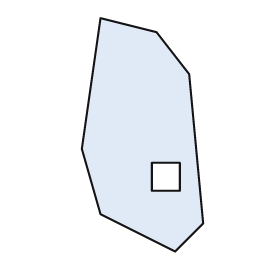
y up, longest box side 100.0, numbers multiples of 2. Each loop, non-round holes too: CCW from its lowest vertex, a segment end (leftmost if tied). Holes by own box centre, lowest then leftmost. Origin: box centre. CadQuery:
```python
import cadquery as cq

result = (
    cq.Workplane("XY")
    .moveTo(14.0, -50.0)
    .lineTo(26.0, -38.0)
    .lineTo(20.0, 26.0)
    .lineTo(6.0, 44.0)
    .lineTo(-18.0, 50.0)
    .lineTo(-26.0, -6.0)
    .lineTo(-18.0, -34.0)
    .close()
    .moveTo(4.0, -24.0)
    .lineTo(16.0, -24.0)
    .lineTo(16.0, -12.0)
    .lineTo(4.0, -12.0)
    .close()
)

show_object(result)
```